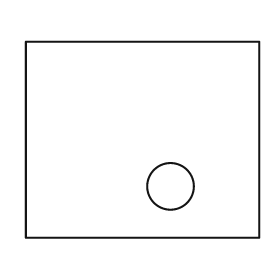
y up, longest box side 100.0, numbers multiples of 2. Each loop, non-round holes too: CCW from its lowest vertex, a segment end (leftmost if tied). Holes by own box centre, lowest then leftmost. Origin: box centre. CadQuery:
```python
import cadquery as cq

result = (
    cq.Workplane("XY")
    .moveTo(-50.0, -42.0)
    .lineTo(50.0, -42.0)
    .lineTo(50.0, 42.0)
    .lineTo(-50.0, 42.0)
    .close()
    .moveTo(12.0, -20.0)
    .circle(10.0)
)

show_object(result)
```